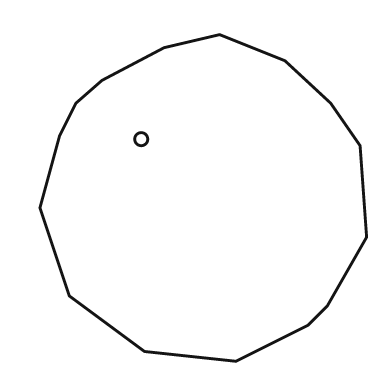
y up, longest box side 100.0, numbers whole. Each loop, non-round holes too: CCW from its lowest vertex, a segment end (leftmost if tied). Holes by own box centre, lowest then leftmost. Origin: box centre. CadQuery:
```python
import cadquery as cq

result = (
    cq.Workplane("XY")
    .moveTo(10.0, -50.0)
    .lineTo(32.0, -39.0)
    .lineTo(38.0, -33.0)
    .lineTo(50.0, -12.0)
    .lineTo(48.0, 16.0)
    .lineTo(39.0, 29.0)
    .lineTo(25.0, 42.0)
    .lineTo(5.0, 50.0)
    .lineTo(-12.0, 46.0)
    .lineTo(-31.0, 36.0)
    .lineTo(-39.0, 29.0)
    .lineTo(-44.0, 19.0)
    .lineTo(-50.0, -3.0)
    .lineTo(-41.0, -30.0)
    .lineTo(-18.0, -47.0)
    .close()
    .moveTo(-19.0, 18.0)
    .circle(2.0)
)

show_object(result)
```